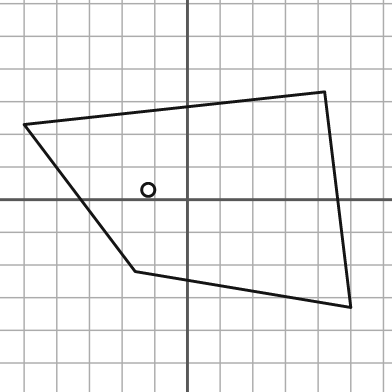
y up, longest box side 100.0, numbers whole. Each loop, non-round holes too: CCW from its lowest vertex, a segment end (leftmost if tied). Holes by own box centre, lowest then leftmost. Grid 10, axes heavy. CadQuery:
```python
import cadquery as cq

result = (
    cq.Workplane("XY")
    .moveTo(50.0, -33.0)
    .lineTo(42.0, 33.0)
    .lineTo(-50.0, 23.0)
    .lineTo(-16.0, -22.0)
    .close()
    .moveTo(-12.0, 3.0)
    .circle(2.0)
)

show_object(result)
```